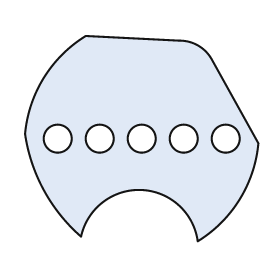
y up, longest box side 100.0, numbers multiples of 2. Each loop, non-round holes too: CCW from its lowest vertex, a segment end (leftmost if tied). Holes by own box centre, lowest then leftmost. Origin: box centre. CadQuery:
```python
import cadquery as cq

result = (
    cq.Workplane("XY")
    .moveTo(24.0, -44.0)
    .threePointArc((42.0, -26.0), (50.0, -2.0))
    .lineTo(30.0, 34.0)
    .threePointArc((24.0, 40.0), (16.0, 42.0))
    .lineTo(-24.0, 44.0)
    .threePointArc((-42.0, 26.0), (-50.0, 2.0))
    .threePointArc((-42.0, -22.0), (-26.0, -42.0))
    .threePointArc((0.0, -22.0), (24.0, -44.0))
    .close()
    .moveTo(-36.0, 0.0)
    .circle(6.0)
    .moveTo(-18.0, 0.0)
    .circle(6.0)
    .moveTo(0.0, 0.0)
    .circle(6.0)
    .moveTo(18.0, 0.0)
    .circle(6.0)
    .moveTo(36.0, 0.0)
    .circle(6.0)
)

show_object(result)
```